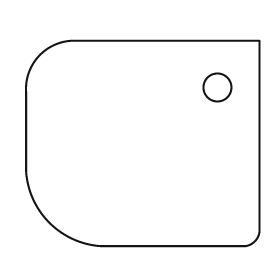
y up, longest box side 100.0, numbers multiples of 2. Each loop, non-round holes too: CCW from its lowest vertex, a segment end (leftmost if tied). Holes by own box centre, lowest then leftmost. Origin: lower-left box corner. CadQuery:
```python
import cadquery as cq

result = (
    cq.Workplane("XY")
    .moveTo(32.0, 0.0)
    .lineTo(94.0, 0.0)
    .threePointArc((98.0, 2.0), (100.0, 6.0))
    .lineTo(100.0, 88.0)
    .lineTo(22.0, 88.0)
    .threePointArc((6.0, 82.0), (0.0, 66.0))
    .lineTo(0.0, 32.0)
    .threePointArc((10.0, 10.0), (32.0, 0.0))
    .close()
    .moveTo(82.0, 68.0)
    .circle(6.0)
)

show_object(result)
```